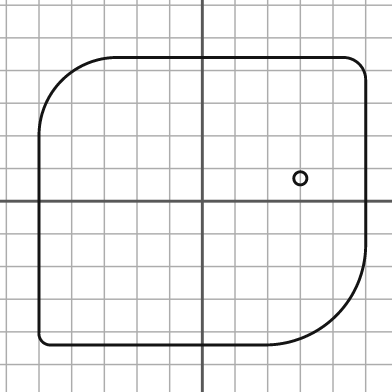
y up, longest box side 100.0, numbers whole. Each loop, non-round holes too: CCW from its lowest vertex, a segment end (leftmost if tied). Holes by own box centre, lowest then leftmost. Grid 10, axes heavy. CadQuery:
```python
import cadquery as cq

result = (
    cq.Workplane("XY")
    .moveTo(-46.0, -44.0)
    .lineTo(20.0, -44.0)
    .threePointArc((41.0, -35.0), (50.0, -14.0))
    .lineTo(50.0, 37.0)
    .threePointArc((48.0, 42.0), (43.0, 44.0))
    .lineTo(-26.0, 44.0)
    .threePointArc((-43.0, 37.0), (-50.0, 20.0))
    .lineTo(-50.0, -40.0)
    .threePointArc((-49.0, -43.0), (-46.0, -44.0))
    .close()
    .moveTo(30.0, 7.0)
    .circle(2.0)
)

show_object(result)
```